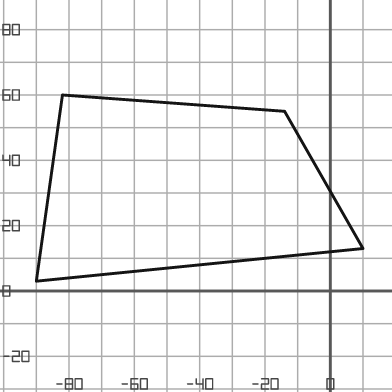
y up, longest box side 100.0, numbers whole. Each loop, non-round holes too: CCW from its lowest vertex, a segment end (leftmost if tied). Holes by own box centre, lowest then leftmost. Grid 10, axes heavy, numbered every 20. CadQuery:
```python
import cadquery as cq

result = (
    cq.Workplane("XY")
    .moveTo(-90.0, 3.0)
    .lineTo(10.0, 13.0)
    .lineTo(-14.0, 55.0)
    .lineTo(-82.0, 60.0)
    .close()
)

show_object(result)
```